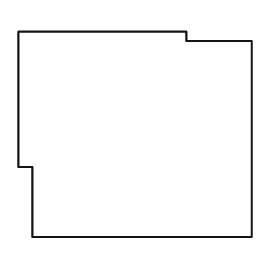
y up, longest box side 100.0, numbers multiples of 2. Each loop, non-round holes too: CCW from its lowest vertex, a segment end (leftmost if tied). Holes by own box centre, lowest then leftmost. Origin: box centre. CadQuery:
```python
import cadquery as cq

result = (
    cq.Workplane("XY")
    .moveTo(-44.0, -44.0)
    .lineTo(50.0, -44.0)
    .lineTo(50.0, 40.0)
    .lineTo(22.0, 40.0)
    .lineTo(22.0, 44.0)
    .lineTo(-50.0, 44.0)
    .lineTo(-50.0, -14.0)
    .lineTo(-44.0, -14.0)
    .close()
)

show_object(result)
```